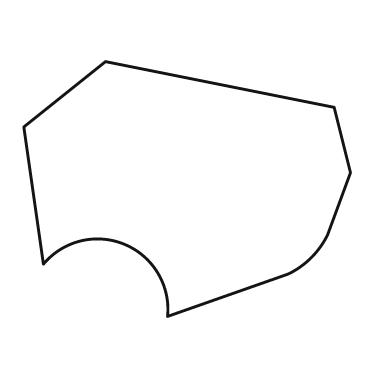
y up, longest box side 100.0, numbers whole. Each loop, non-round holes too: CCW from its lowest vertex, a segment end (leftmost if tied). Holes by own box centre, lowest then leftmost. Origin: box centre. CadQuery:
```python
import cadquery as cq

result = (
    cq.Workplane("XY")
    .moveTo(-6.0, -39.0)
    .lineTo(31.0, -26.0)
    .threePointArc((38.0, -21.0), (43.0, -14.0))
    .lineTo(50.0, 5.0)
    .lineTo(45.0, 25.0)
    .lineTo(-25.0, 39.0)
    .lineTo(-50.0, 19.0)
    .lineTo(-44.0, -23.0)
    .threePointArc((-19.0, -17.0), (-6.0, -39.0))
    .close()
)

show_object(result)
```